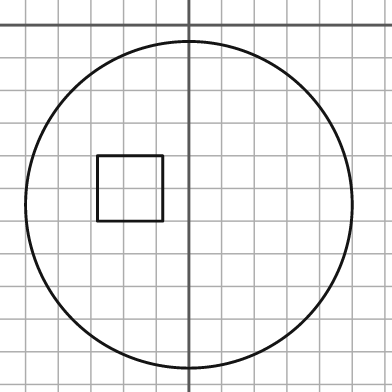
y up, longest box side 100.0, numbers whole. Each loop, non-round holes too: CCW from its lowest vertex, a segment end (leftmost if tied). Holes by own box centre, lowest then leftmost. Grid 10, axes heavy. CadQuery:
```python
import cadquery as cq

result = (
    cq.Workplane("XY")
    .moveTo(0.0, -55.0)
    .circle(50.0)
    .moveTo(-28.0, -60.0)
    .lineTo(-8.0, -60.0)
    .lineTo(-8.0, -40.0)
    .lineTo(-28.0, -40.0)
    .close()
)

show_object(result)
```